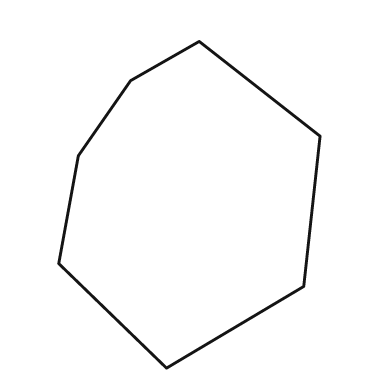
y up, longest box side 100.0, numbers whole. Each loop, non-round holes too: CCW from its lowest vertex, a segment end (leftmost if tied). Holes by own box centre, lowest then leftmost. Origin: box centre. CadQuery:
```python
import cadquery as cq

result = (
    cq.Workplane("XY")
    .moveTo(-7.0, -50.0)
    .lineTo(35.0, -25.0)
    .lineTo(40.0, 21.0)
    .lineTo(3.0, 50.0)
    .lineTo(-18.0, 38.0)
    .lineTo(-34.0, 15.0)
    .lineTo(-40.0, -18.0)
    .close()
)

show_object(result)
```